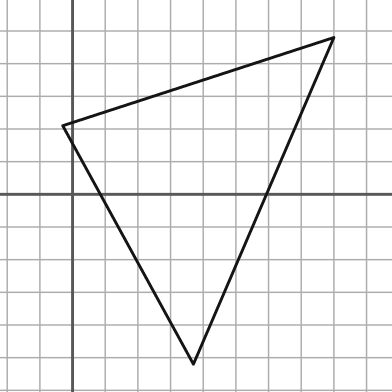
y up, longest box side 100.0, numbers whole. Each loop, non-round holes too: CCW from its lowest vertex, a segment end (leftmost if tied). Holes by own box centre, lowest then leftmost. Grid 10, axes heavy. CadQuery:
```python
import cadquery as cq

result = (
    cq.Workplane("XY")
    .moveTo(37.0, -52.0)
    .lineTo(80.0, 48.0)
    .lineTo(-3.0, 21.0)
    .close()
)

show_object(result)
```